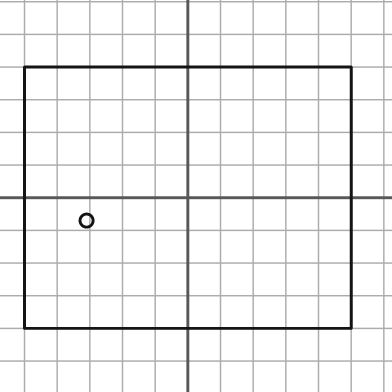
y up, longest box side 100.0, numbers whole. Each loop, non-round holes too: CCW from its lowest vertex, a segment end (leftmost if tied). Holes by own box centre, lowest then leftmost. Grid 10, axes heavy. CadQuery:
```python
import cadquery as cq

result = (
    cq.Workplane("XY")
    .moveTo(-50.0, -40.0)
    .lineTo(50.0, -40.0)
    .lineTo(50.0, 40.0)
    .lineTo(-50.0, 40.0)
    .close()
    .moveTo(-31.0, -7.0)
    .circle(2.0)
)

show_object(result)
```